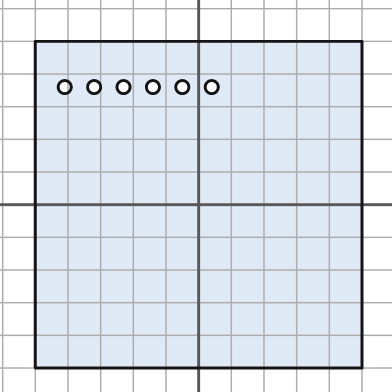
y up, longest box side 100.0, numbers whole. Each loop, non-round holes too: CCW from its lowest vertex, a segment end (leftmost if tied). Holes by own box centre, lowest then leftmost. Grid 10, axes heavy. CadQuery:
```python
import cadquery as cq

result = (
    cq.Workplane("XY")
    .moveTo(-50.0, -50.0)
    .lineTo(50.0, -50.0)
    .lineTo(50.0, 50.0)
    .lineTo(-50.0, 50.0)
    .close()
    .moveTo(-41.0, 36.0)
    .circle(2.0)
    .moveTo(-32.0, 36.0)
    .circle(2.0)
    .moveTo(-23.0, 36.0)
    .circle(2.0)
    .moveTo(-14.0, 36.0)
    .circle(2.0)
    .moveTo(-5.0, 36.0)
    .circle(2.0)
    .moveTo(4.0, 36.0)
    .circle(2.0)
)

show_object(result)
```